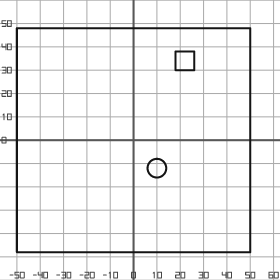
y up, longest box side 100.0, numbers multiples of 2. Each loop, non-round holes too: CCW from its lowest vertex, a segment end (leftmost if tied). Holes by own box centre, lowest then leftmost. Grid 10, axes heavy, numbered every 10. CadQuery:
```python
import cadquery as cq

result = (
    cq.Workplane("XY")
    .moveTo(-50.0, -48.0)
    .lineTo(50.0, -48.0)
    .lineTo(50.0, 48.0)
    .lineTo(-50.0, 48.0)
    .close()
    .moveTo(10.0, -12.0)
    .circle(4.0)
    .moveTo(18.0, 30.0)
    .lineTo(26.0, 30.0)
    .lineTo(26.0, 38.0)
    .lineTo(18.0, 38.0)
    .close()
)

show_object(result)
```